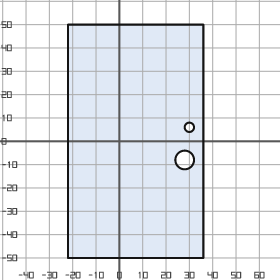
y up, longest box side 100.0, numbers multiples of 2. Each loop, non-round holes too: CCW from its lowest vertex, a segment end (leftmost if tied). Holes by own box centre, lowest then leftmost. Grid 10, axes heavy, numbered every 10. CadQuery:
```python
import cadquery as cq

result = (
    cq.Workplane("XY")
    .moveTo(-22.0, -50.0)
    .lineTo(36.0, -50.0)
    .lineTo(36.0, 50.0)
    .lineTo(-22.0, 50.0)
    .close()
    .moveTo(28.0, -8.0)
    .circle(4.0)
    .moveTo(30.0, 6.0)
    .circle(2.0)
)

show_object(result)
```